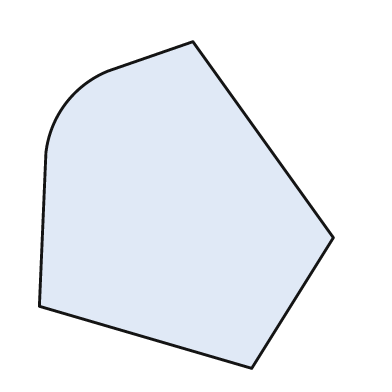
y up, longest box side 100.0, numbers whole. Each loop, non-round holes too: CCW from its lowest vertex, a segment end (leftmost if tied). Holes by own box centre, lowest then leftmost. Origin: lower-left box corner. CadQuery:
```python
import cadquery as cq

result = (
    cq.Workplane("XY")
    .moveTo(65.0, 0.0)
    .lineTo(90.0, 40.0)
    .lineTo(47.0, 100.0)
    .lineTo(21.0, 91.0)
    .threePointArc((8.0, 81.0), (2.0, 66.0))
    .lineTo(0.0, 19.0)
    .close()
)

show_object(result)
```